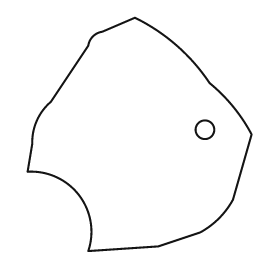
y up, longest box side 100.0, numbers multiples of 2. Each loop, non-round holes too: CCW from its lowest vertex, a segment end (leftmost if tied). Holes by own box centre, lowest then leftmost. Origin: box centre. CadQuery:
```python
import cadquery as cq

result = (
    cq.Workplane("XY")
    .moveTo(-22.0, -50.0)
    .lineTo(8.0, -48.0)
    .lineTo(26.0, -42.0)
    .threePointArc((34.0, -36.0), (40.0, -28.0))
    .lineTo(48.0, 0.0)
    .threePointArc((40.0, 12.0), (30.0, 22.0))
    .threePointArc((16.0, 38.0), (-2.0, 50.0))
    .lineTo(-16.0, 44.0)
    .threePointArc((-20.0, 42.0), (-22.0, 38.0))
    .lineTo(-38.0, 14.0)
    .threePointArc((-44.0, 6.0), (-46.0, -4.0))
    .lineTo(-48.0, -16.0)
    .threePointArc((-26.0, -26.0), (-22.0, -50.0))
    .close()
    .moveTo(28.0, 2.0)
    .circle(4.0)
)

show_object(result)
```